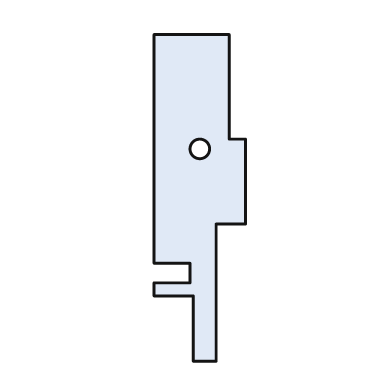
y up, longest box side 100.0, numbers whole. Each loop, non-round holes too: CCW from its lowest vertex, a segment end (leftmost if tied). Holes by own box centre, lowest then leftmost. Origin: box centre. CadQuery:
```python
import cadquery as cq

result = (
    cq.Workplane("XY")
    .moveTo(-2.0, -50.0)
    .lineTo(5.0, -50.0)
    .lineTo(5.0, -8.0)
    .lineTo(14.0, -8.0)
    .lineTo(14.0, 18.0)
    .lineTo(9.0, 18.0)
    .lineTo(9.0, 50.0)
    .lineTo(-14.0, 50.0)
    .lineTo(-14.0, -20.0)
    .lineTo(-3.0, -20.0)
    .lineTo(-3.0, -26.0)
    .lineTo(-14.0, -26.0)
    .lineTo(-14.0, -30.0)
    .lineTo(-2.0, -30.0)
    .close()
    .moveTo(0.0, 15.0)
    .circle(3.0)
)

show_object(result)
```